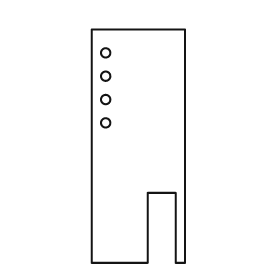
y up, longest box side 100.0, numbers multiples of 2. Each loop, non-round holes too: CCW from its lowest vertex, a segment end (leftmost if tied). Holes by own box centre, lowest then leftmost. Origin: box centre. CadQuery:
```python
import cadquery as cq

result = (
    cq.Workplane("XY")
    .moveTo(-20.0, -50.0)
    .lineTo(4.0, -50.0)
    .lineTo(4.0, -20.0)
    .lineTo(16.0, -20.0)
    .lineTo(16.0, -50.0)
    .lineTo(20.0, -50.0)
    .lineTo(20.0, 50.0)
    .lineTo(-20.0, 50.0)
    .close()
    .moveTo(-14.0, 10.0)
    .circle(2.0)
    .moveTo(-14.0, 20.0)
    .circle(2.0)
    .moveTo(-14.0, 30.0)
    .circle(2.0)
    .moveTo(-14.0, 40.0)
    .circle(2.0)
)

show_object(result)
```